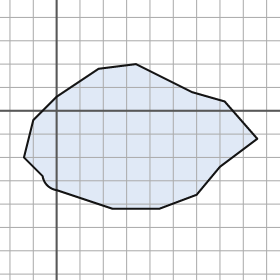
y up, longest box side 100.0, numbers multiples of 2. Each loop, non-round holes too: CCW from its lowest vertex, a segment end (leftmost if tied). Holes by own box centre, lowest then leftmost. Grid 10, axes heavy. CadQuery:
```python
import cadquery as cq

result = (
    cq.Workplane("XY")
    .moveTo(24.0, -42.0)
    .lineTo(44.0, -42.0)
    .lineTo(60.0, -36.0)
    .lineTo(70.0, -24.0)
    .lineTo(86.0, -12.0)
    .lineTo(72.0, 4.0)
    .lineTo(58.0, 8.0)
    .lineTo(34.0, 20.0)
    .lineTo(18.0, 18.0)
    .lineTo(0.0, 6.0)
    .lineTo(-10.0, -4.0)
    .lineTo(-14.0, -20.0)
    .lineTo(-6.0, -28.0)
    .threePointArc((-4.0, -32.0), (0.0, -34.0))
    .close()
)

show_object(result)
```